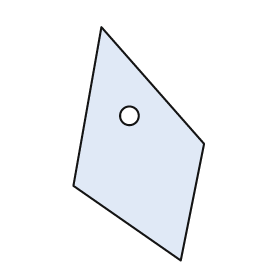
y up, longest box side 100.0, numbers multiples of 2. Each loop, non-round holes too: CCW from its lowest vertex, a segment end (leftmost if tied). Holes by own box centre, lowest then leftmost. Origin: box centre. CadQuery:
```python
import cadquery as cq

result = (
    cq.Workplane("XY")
    .moveTo(18.0, -50.0)
    .lineTo(28.0, 0.0)
    .lineTo(-16.0, 50.0)
    .lineTo(-28.0, -18.0)
    .close()
    .moveTo(-4.0, 12.0)
    .circle(4.0)
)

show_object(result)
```